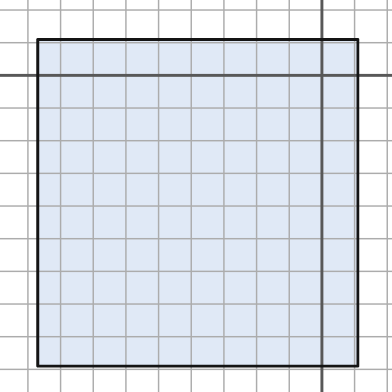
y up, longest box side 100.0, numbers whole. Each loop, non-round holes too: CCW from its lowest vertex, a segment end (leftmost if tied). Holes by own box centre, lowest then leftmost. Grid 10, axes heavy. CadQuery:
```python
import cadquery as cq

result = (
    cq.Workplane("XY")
    .moveTo(-87.0, -89.0)
    .lineTo(11.0, -89.0)
    .lineTo(11.0, 11.0)
    .lineTo(-87.0, 11.0)
    .close()
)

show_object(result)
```